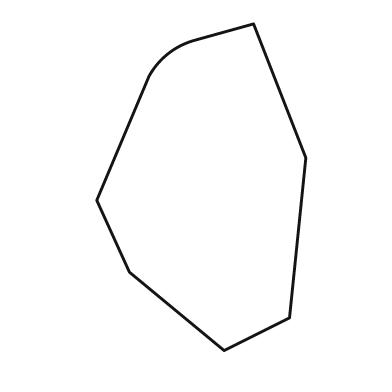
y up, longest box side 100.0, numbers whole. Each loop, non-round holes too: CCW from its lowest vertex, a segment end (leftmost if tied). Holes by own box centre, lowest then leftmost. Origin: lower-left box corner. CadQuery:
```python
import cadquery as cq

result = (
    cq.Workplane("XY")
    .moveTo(39.0, 0.0)
    .lineTo(59.0, 10.0)
    .lineTo(64.0, 59.0)
    .lineTo(48.0, 100.0)
    .lineTo(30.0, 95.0)
    .threePointArc((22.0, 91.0), (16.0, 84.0))
    .lineTo(0.0, 46.0)
    .lineTo(10.0, 24.0)
    .close()
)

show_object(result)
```